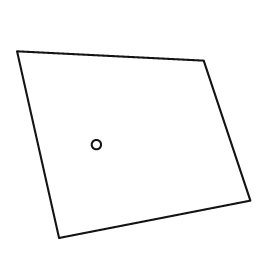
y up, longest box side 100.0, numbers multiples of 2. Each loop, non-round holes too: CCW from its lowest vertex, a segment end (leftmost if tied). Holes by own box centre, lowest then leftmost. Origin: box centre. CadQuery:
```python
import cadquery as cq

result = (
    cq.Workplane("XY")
    .moveTo(-32.0, -40.0)
    .lineTo(50.0, -24.0)
    .lineTo(30.0, 36.0)
    .lineTo(-50.0, 40.0)
    .close()
    .moveTo(-16.0, 0.0)
    .circle(2.0)
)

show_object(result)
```